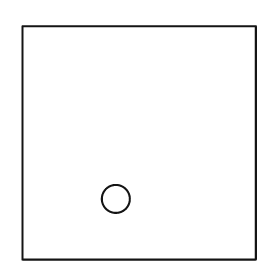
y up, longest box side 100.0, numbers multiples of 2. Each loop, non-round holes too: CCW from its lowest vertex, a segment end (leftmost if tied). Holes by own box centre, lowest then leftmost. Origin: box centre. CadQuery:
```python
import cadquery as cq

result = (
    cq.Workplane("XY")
    .moveTo(-50.0, -50.0)
    .lineTo(50.0, -50.0)
    .lineTo(50.0, 50.0)
    .lineTo(-50.0, 50.0)
    .close()
    .moveTo(-10.0, -24.0)
    .circle(6.0)
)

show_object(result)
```